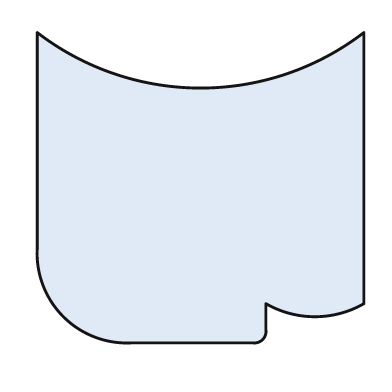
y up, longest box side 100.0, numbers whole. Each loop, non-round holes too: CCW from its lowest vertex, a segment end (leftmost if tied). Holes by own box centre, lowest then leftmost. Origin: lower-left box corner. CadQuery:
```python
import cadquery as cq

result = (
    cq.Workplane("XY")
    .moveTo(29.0, 0.0)
    .lineTo(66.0, 0.0)
    .threePointArc((69.0, 1.0), (70.0, 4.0))
    .lineTo(70.0, 12.0)
    .threePointArc((85.0, 8.0), (100.0, 12.0))
    .lineTo(100.0, 95.0)
    .threePointArc((50.0, 78.0), (0.0, 95.0))
    .lineTo(0.0, 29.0)
    .threePointArc((8.0, 8.0), (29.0, 0.0))
    .close()
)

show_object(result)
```